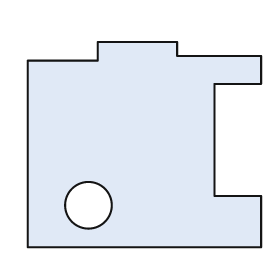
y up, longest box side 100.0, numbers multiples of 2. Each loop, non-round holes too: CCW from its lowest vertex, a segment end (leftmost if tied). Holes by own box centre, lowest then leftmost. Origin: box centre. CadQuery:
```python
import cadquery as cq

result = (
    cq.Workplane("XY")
    .moveTo(-50.0, -44.0)
    .lineTo(50.0, -44.0)
    .lineTo(50.0, -22.0)
    .lineTo(30.0, -22.0)
    .lineTo(30.0, 26.0)
    .lineTo(50.0, 26.0)
    .lineTo(50.0, 38.0)
    .lineTo(14.0, 38.0)
    .lineTo(14.0, 44.0)
    .lineTo(-20.0, 44.0)
    .lineTo(-20.0, 36.0)
    .lineTo(-50.0, 36.0)
    .close()
    .moveTo(-24.0, -26.0)
    .circle(10.0)
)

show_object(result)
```